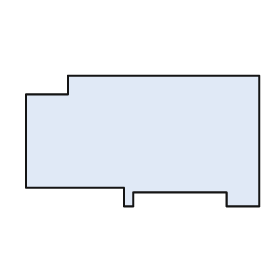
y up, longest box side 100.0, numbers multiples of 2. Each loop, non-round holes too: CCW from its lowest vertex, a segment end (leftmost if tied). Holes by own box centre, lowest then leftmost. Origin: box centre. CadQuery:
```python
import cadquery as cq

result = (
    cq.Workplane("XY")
    .moveTo(-8.0, -28.0)
    .lineTo(-4.0, -28.0)
    .lineTo(-4.0, -22.0)
    .lineTo(36.0, -22.0)
    .lineTo(36.0, -28.0)
    .lineTo(50.0, -28.0)
    .lineTo(50.0, 28.0)
    .lineTo(-32.0, 28.0)
    .lineTo(-32.0, 20.0)
    .lineTo(-50.0, 20.0)
    .lineTo(-50.0, -20.0)
    .lineTo(-8.0, -20.0)
    .close()
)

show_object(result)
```